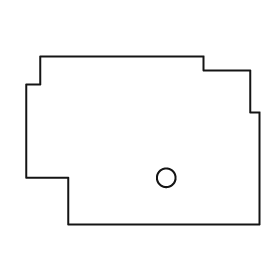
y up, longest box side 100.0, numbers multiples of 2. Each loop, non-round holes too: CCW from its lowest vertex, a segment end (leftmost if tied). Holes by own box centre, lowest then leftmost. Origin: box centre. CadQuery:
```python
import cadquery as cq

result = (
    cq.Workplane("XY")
    .moveTo(-32.0, -36.0)
    .lineTo(50.0, -36.0)
    .lineTo(50.0, 12.0)
    .lineTo(46.0, 12.0)
    .lineTo(46.0, 30.0)
    .lineTo(26.0, 30.0)
    .lineTo(26.0, 36.0)
    .lineTo(-44.0, 36.0)
    .lineTo(-44.0, 24.0)
    .lineTo(-50.0, 24.0)
    .lineTo(-50.0, -16.0)
    .lineTo(-32.0, -16.0)
    .close()
    .moveTo(10.0, -16.0)
    .circle(4.0)
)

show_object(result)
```